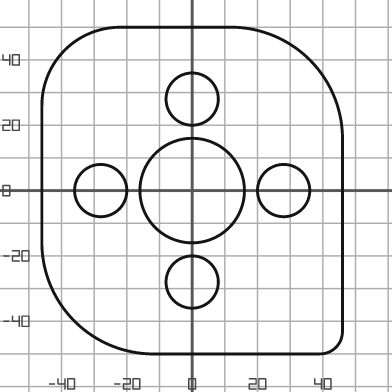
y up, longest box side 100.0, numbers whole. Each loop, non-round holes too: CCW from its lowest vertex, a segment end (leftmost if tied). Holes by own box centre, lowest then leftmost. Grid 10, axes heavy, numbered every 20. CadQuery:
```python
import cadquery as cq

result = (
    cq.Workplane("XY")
    .moveTo(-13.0, -50.0)
    .lineTo(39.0, -50.0)
    .threePointArc((44.0, -48.0), (46.0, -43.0))
    .lineTo(46.0, 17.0)
    .threePointArc((36.0, 40.0), (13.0, 50.0))
    .lineTo(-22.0, 50.0)
    .threePointArc((-39.0, 43.0), (-46.0, 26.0))
    .lineTo(-46.0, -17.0)
    .threePointArc((-36.0, -40.0), (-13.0, -50.0))
    .close()
    .moveTo(0.0, -28.0)
    .circle(8.0)
    .moveTo(-28.0, 0.0)
    .circle(8.0)
    .moveTo(0.0, 0.0)
    .circle(16.0)
    .moveTo(28.0, 0.0)
    .circle(8.0)
    .moveTo(0.0, 28.0)
    .circle(8.0)
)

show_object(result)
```